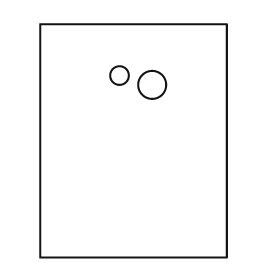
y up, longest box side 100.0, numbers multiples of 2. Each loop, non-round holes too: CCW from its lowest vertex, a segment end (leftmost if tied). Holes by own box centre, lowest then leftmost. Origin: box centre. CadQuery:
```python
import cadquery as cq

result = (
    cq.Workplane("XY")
    .moveTo(-40.0, -50.0)
    .lineTo(40.0, -50.0)
    .lineTo(40.0, 50.0)
    .lineTo(-40.0, 50.0)
    .close()
    .moveTo(8.0, 24.0)
    .circle(6.0)
    .moveTo(-6.0, 28.0)
    .circle(4.0)
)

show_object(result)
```